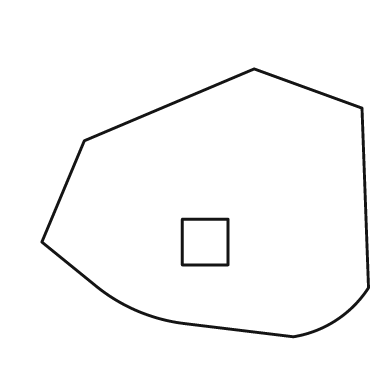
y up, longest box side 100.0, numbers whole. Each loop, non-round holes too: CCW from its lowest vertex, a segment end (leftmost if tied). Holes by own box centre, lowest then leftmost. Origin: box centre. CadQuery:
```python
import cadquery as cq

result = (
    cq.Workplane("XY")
    .moveTo(27.0, -41.0)
    .threePointArc((40.0, -36.0), (50.0, -26.0))
    .lineTo(48.0, 29.0)
    .lineTo(15.0, 41.0)
    .lineTo(-37.0, 19.0)
    .lineTo(-50.0, -12.0)
    .lineTo(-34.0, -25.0)
    .threePointArc((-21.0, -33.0), (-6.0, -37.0))
    .close()
    .moveTo(-7.0, -19.0)
    .lineTo(7.0, -19.0)
    .lineTo(7.0, -5.0)
    .lineTo(-7.0, -5.0)
    .close()
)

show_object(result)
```